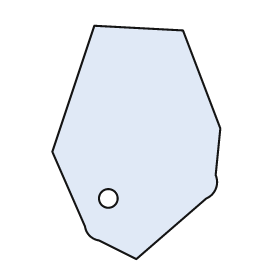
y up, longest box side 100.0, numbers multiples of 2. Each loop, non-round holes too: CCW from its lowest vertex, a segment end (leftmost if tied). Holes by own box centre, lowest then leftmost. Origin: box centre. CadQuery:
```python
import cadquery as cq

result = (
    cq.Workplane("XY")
    .moveTo(0.0, -50.0)
    .lineTo(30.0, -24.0)
    .threePointArc((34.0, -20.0), (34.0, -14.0))
    .lineTo(36.0, 6.0)
    .lineTo(20.0, 48.0)
    .lineTo(-18.0, 50.0)
    .lineTo(-36.0, -4.0)
    .lineTo(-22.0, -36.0)
    .threePointArc((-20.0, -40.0), (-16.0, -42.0))
    .close()
    .moveTo(-12.0, -24.0)
    .circle(4.0)
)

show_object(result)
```